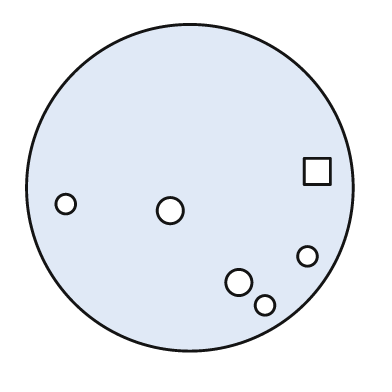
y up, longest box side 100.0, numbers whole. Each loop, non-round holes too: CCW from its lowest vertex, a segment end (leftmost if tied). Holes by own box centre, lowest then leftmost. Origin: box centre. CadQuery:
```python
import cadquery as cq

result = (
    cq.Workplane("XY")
    .moveTo(0.0, 0.0)
    .circle(50.0)
    .moveTo(23.0, -36.0)
    .circle(3.0)
    .moveTo(15.0, -29.0)
    .circle(4.0)
    .moveTo(36.0, -21.0)
    .circle(3.0)
    .moveTo(-6.0, -7.0)
    .circle(4.0)
    .moveTo(-38.0, -5.0)
    .circle(3.0)
    .moveTo(35.0, 1.0)
    .lineTo(43.0, 1.0)
    .lineTo(43.0, 9.0)
    .lineTo(35.0, 9.0)
    .close()
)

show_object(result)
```